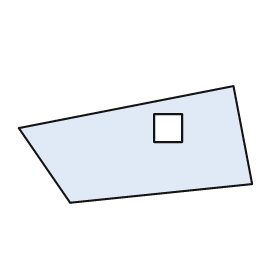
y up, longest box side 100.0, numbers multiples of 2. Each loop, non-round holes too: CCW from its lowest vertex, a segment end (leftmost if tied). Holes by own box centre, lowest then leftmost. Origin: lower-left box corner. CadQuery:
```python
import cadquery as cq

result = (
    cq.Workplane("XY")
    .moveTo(22.0, 0.0)
    .lineTo(100.0, 8.0)
    .lineTo(92.0, 50.0)
    .lineTo(0.0, 32.0)
    .close()
    .moveTo(58.0, 26.0)
    .lineTo(70.0, 26.0)
    .lineTo(70.0, 38.0)
    .lineTo(58.0, 38.0)
    .close()
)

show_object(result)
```